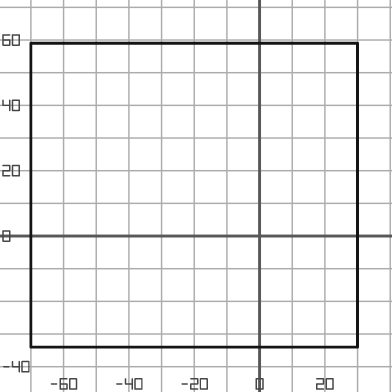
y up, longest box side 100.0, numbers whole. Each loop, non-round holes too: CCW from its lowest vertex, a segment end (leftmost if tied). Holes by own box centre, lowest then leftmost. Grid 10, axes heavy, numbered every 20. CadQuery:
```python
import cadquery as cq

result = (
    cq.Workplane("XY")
    .moveTo(-70.0, -34.0)
    .lineTo(30.0, -34.0)
    .lineTo(30.0, 59.0)
    .lineTo(-70.0, 59.0)
    .close()
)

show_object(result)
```